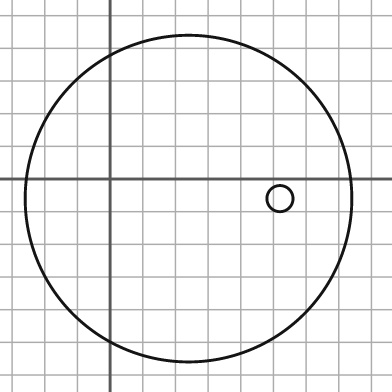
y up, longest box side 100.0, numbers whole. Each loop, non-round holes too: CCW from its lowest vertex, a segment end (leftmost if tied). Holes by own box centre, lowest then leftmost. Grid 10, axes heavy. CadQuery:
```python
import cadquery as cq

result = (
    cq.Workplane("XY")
    .moveTo(24.0, -6.0)
    .circle(50.0)
    .moveTo(52.0, -6.0)
    .circle(4.0)
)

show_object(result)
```